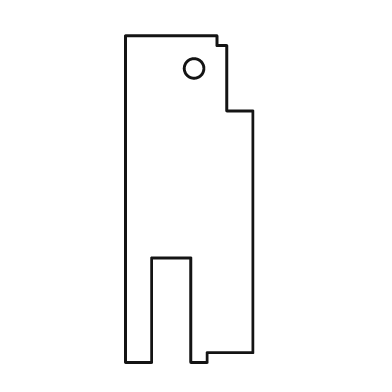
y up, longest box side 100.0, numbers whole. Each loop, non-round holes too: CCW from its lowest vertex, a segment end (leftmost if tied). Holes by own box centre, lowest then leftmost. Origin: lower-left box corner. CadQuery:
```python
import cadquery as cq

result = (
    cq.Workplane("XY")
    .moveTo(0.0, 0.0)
    .lineTo(8.0, 0.0)
    .lineTo(8.0, 32.0)
    .lineTo(20.0, 32.0)
    .lineTo(20.0, 0.0)
    .lineTo(25.0, 0.0)
    .lineTo(25.0, 3.0)
    .lineTo(39.0, 3.0)
    .lineTo(39.0, 77.0)
    .lineTo(31.0, 77.0)
    .lineTo(31.0, 97.0)
    .lineTo(28.0, 97.0)
    .lineTo(28.0, 100.0)
    .lineTo(0.0, 100.0)
    .close()
    .moveTo(21.0, 90.0)
    .circle(3.0)
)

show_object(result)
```